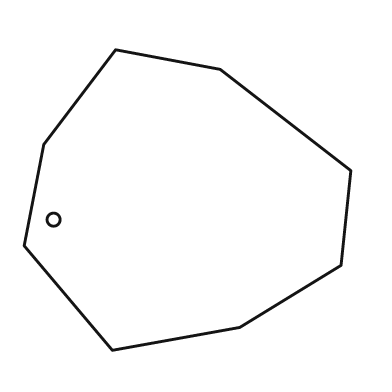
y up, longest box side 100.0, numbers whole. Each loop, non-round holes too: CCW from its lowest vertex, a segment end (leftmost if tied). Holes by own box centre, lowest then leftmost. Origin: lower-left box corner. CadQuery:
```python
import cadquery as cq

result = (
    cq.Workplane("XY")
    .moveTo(27.0, 0.0)
    .lineTo(66.0, 7.0)
    .lineTo(97.0, 26.0)
    .lineTo(100.0, 55.0)
    .lineTo(60.0, 86.0)
    .lineTo(28.0, 92.0)
    .lineTo(6.0, 63.0)
    .lineTo(0.0, 32.0)
    .close()
    .moveTo(9.0, 40.0)
    .circle(2.0)
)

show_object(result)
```